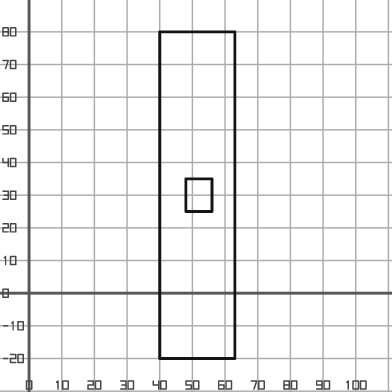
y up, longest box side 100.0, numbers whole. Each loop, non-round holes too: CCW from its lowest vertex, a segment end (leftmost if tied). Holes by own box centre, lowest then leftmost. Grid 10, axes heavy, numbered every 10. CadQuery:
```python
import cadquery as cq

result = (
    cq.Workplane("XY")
    .moveTo(40.0, -20.0)
    .lineTo(63.0, -20.0)
    .lineTo(63.0, 80.0)
    .lineTo(40.0, 80.0)
    .close()
    .moveTo(48.0, 25.0)
    .lineTo(56.0, 25.0)
    .lineTo(56.0, 35.0)
    .lineTo(48.0, 35.0)
    .close()
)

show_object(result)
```